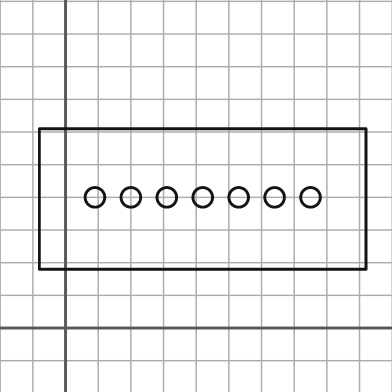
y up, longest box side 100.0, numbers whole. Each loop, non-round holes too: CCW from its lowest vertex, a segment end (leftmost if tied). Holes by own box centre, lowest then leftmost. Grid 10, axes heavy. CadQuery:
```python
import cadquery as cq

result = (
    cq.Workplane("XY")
    .moveTo(-8.0, 18.0)
    .lineTo(92.0, 18.0)
    .lineTo(92.0, 61.0)
    .lineTo(-8.0, 61.0)
    .close()
    .moveTo(9.0, 40.0)
    .circle(3.0)
    .moveTo(20.0, 40.0)
    .circle(3.0)
    .moveTo(31.0, 40.0)
    .circle(3.0)
    .moveTo(42.0, 40.0)
    .circle(3.0)
    .moveTo(53.0, 40.0)
    .circle(3.0)
    .moveTo(64.0, 40.0)
    .circle(3.0)
    .moveTo(75.0, 40.0)
    .circle(3.0)
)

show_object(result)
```